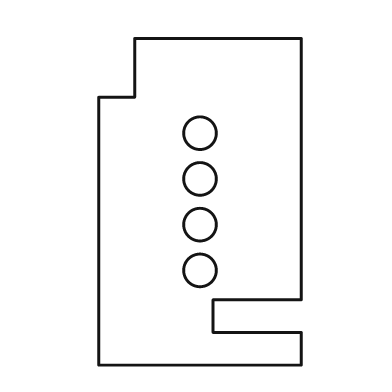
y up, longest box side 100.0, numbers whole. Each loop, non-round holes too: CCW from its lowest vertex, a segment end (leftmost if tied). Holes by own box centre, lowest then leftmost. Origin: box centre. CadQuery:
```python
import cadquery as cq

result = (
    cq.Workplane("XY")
    .moveTo(-31.0, -50.0)
    .lineTo(31.0, -50.0)
    .lineTo(31.0, -40.0)
    .lineTo(4.0, -40.0)
    .lineTo(4.0, -30.0)
    .lineTo(31.0, -30.0)
    .lineTo(31.0, 50.0)
    .lineTo(-20.0, 50.0)
    .lineTo(-20.0, 32.0)
    .lineTo(-31.0, 32.0)
    .close()
    .moveTo(0.0, -21.0)
    .circle(5.0)
    .moveTo(0.0, -7.0)
    .circle(5.0)
    .moveTo(0.0, 7.0)
    .circle(5.0)
    .moveTo(0.0, 21.0)
    .circle(5.0)
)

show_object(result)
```